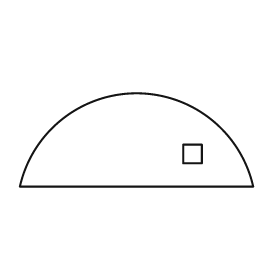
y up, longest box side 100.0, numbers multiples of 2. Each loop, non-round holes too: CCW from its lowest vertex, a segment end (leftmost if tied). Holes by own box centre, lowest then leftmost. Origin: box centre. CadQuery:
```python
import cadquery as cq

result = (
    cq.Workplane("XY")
    .moveTo(-50.0, -20.0)
    .lineTo(50.0, -20.0)
    .threePointArc((0.0, 20.0), (-50.0, -20.0))
    .close()
    .moveTo(20.0, -10.0)
    .lineTo(28.0, -10.0)
    .lineTo(28.0, -2.0)
    .lineTo(20.0, -2.0)
    .close()
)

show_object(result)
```